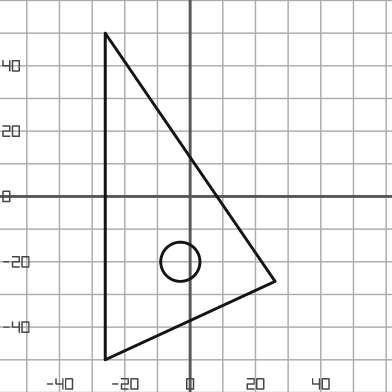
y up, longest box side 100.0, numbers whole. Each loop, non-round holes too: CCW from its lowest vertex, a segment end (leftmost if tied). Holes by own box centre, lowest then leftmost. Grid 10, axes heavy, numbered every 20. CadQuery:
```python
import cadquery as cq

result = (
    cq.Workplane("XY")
    .moveTo(-26.0, -50.0)
    .lineTo(26.0, -26.0)
    .lineTo(-26.0, 50.0)
    .close()
    .moveTo(-3.0, -20.0)
    .circle(6.0)
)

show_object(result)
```